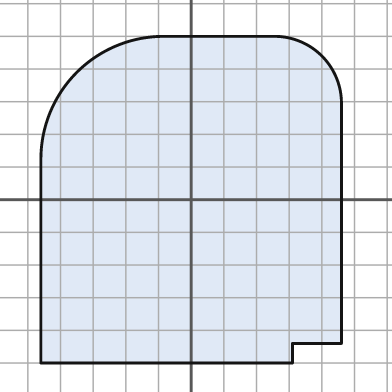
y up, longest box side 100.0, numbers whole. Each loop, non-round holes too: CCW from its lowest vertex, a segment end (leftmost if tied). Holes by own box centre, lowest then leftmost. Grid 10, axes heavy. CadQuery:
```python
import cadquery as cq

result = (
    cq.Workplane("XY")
    .moveTo(-46.0, -50.0)
    .lineTo(31.0, -50.0)
    .lineTo(31.0, -44.0)
    .lineTo(46.0, -44.0)
    .lineTo(46.0, 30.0)
    .threePointArc((40.0, 44.0), (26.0, 50.0))
    .lineTo(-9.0, 50.0)
    .threePointArc((-35.0, 39.0), (-46.0, 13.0))
    .close()
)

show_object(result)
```